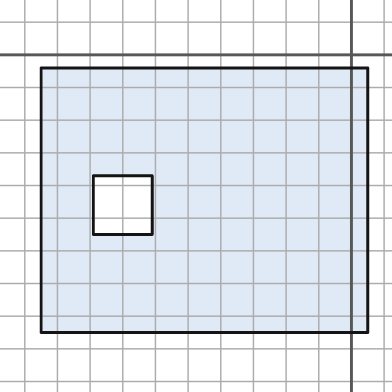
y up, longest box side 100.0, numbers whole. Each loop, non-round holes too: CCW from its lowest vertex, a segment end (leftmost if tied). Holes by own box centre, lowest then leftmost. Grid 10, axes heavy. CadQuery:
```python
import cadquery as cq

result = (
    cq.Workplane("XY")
    .moveTo(-95.0, -85.0)
    .lineTo(5.0, -85.0)
    .lineTo(5.0, -4.0)
    .lineTo(-95.0, -4.0)
    .close()
    .moveTo(-79.0, -55.0)
    .lineTo(-61.0, -55.0)
    .lineTo(-61.0, -37.0)
    .lineTo(-79.0, -37.0)
    .close()
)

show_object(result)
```